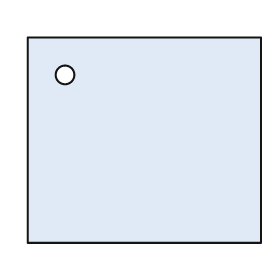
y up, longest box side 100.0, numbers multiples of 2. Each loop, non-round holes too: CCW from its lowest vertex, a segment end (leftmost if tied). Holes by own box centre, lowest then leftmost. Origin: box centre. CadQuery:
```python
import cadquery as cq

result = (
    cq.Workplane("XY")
    .moveTo(-50.0, -44.0)
    .lineTo(50.0, -44.0)
    .lineTo(50.0, 44.0)
    .lineTo(-50.0, 44.0)
    .close()
    .moveTo(-34.0, 28.0)
    .circle(4.0)
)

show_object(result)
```